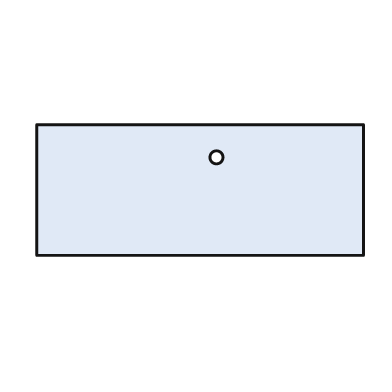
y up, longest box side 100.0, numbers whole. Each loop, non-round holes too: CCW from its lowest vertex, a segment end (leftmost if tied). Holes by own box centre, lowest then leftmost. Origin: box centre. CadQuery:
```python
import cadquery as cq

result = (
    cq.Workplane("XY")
    .moveTo(-50.0, -20.0)
    .lineTo(50.0, -20.0)
    .lineTo(50.0, 20.0)
    .lineTo(-50.0, 20.0)
    .close()
    .moveTo(5.0, 10.0)
    .circle(2.0)
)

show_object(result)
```